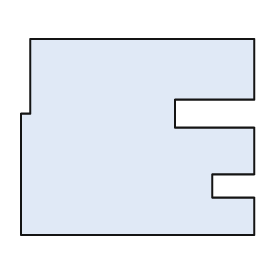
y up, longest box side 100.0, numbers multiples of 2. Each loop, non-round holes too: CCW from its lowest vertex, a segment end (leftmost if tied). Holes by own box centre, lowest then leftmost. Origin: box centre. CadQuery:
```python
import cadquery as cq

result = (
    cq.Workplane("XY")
    .moveTo(-50.0, -42.0)
    .lineTo(50.0, -42.0)
    .lineTo(50.0, -26.0)
    .lineTo(32.0, -26.0)
    .lineTo(32.0, -16.0)
    .lineTo(50.0, -16.0)
    .lineTo(50.0, 4.0)
    .lineTo(16.0, 4.0)
    .lineTo(16.0, 16.0)
    .lineTo(50.0, 16.0)
    .lineTo(50.0, 42.0)
    .lineTo(-46.0, 42.0)
    .lineTo(-46.0, 10.0)
    .lineTo(-50.0, 10.0)
    .close()
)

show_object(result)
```